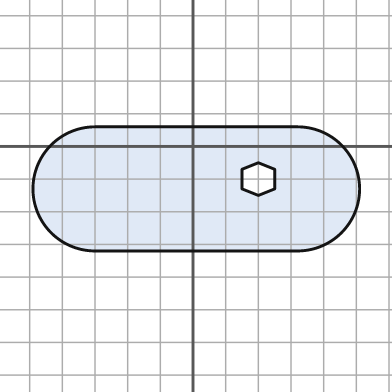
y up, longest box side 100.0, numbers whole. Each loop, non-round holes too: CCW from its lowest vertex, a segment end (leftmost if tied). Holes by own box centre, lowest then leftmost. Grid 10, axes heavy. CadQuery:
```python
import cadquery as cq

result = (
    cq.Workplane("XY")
    .moveTo(-30.0, -32.0)
    .lineTo(32.0, -32.0)
    .threePointArc((51.0, -13.0), (32.0, 6.0))
    .lineTo(-30.0, 6.0)
    .threePointArc((-49.0, -13.0), (-30.0, -32.0))
    .close()
    .moveTo(20.0, -15.0)
    .lineTo(25.0, -13.0)
    .lineTo(25.0, -7.0)
    .lineTo(20.0, -5.0)
    .lineTo(15.0, -7.0)
    .lineTo(15.0, -13.0)
    .close()
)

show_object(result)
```